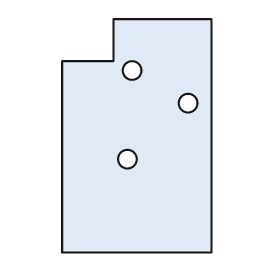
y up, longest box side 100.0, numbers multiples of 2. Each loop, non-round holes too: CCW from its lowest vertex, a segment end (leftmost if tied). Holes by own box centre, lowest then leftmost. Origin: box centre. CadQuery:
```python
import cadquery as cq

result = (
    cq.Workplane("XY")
    .moveTo(-32.0, -50.0)
    .lineTo(32.0, -50.0)
    .lineTo(32.0, 50.0)
    .lineTo(-10.0, 50.0)
    .lineTo(-10.0, 32.0)
    .lineTo(-32.0, 32.0)
    .close()
    .moveTo(-4.0, -10.0)
    .circle(4.0)
    .moveTo(22.0, 14.0)
    .circle(4.0)
    .moveTo(-2.0, 28.0)
    .circle(4.0)
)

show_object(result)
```